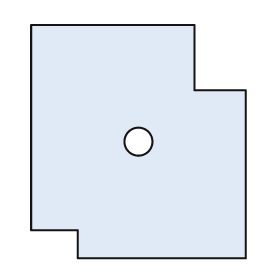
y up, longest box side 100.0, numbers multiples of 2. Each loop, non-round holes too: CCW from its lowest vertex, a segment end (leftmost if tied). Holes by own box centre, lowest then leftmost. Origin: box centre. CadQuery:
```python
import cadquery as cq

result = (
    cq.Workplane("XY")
    .moveTo(-26.0, -50.0)
    .lineTo(46.0, -50.0)
    .lineTo(46.0, 22.0)
    .lineTo(24.0, 22.0)
    .lineTo(24.0, 50.0)
    .lineTo(-46.0, 50.0)
    .lineTo(-46.0, -38.0)
    .lineTo(-26.0, -38.0)
    .close()
    .moveTo(0.0, 0.0)
    .circle(6.0)
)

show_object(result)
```